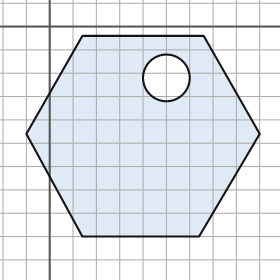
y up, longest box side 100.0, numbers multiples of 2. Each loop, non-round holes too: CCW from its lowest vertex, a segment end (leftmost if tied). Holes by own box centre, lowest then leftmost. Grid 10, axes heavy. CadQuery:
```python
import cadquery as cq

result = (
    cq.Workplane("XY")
    .moveTo(14.0, -90.0)
    .lineTo(64.0, -90.0)
    .lineTo(90.0, -46.0)
    .lineTo(66.0, -4.0)
    .lineTo(14.0, -4.0)
    .lineTo(-10.0, -46.0)
    .close()
    .moveTo(50.0, -22.0)
    .circle(10.0)
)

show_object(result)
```